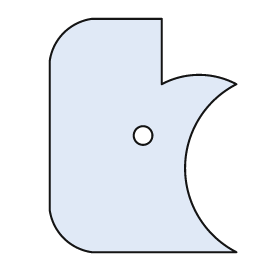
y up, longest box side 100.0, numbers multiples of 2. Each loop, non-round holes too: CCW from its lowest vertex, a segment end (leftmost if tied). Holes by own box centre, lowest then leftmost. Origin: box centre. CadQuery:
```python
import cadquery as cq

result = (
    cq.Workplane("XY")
    .moveTo(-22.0, -50.0)
    .lineTo(40.0, -50.0)
    .threePointArc((18.0, -14.0), (40.0, 22.0))
    .threePointArc((24.0, 26.0), (8.0, 22.0))
    .lineTo(8.0, 50.0)
    .lineTo(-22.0, 50.0)
    .threePointArc((-34.0, 44.0), (-40.0, 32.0))
    .lineTo(-40.0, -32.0)
    .threePointArc((-34.0, -44.0), (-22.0, -50.0))
    .close()
    .moveTo(0.0, 0.0)
    .circle(4.0)
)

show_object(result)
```